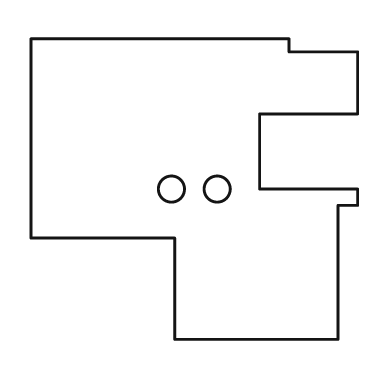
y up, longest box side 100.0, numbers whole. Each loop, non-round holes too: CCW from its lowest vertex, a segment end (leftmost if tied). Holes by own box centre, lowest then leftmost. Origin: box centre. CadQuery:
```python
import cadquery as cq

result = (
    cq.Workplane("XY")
    .moveTo(-6.0, -46.0)
    .lineTo(44.0, -46.0)
    .lineTo(44.0, -5.0)
    .lineTo(50.0, -5.0)
    .lineTo(50.0, 0.0)
    .lineTo(20.0, 0.0)
    .lineTo(20.0, 23.0)
    .lineTo(50.0, 23.0)
    .lineTo(50.0, 42.0)
    .lineTo(29.0, 42.0)
    .lineTo(29.0, 46.0)
    .lineTo(-50.0, 46.0)
    .lineTo(-50.0, -15.0)
    .lineTo(-6.0, -15.0)
    .close()
    .moveTo(-7.0, 0.0)
    .circle(4.0)
    .moveTo(7.0, 0.0)
    .circle(4.0)
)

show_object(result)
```